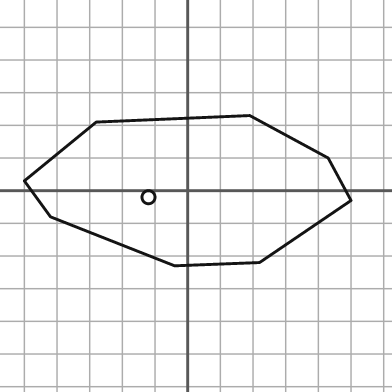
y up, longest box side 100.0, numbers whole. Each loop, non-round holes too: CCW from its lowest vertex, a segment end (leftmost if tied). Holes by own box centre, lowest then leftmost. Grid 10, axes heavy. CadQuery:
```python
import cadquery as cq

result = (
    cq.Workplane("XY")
    .moveTo(-4.0, -23.0)
    .lineTo(22.0, -22.0)
    .lineTo(50.0, -3.0)
    .lineTo(43.0, 10.0)
    .lineTo(19.0, 23.0)
    .lineTo(-28.0, 21.0)
    .lineTo(-50.0, 3.0)
    .lineTo(-42.0, -8.0)
    .close()
    .moveTo(-12.0, -2.0)
    .circle(2.0)
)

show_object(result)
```